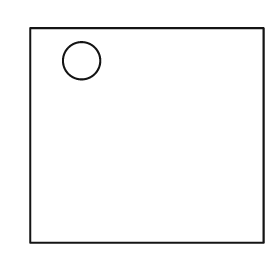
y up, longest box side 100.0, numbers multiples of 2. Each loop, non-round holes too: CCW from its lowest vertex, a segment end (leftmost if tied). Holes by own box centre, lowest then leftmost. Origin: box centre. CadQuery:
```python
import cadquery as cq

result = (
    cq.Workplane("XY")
    .moveTo(-50.0, -46.0)
    .lineTo(50.0, -46.0)
    .lineTo(50.0, 46.0)
    .lineTo(-50.0, 46.0)
    .close()
    .moveTo(-28.0, 32.0)
    .circle(8.0)
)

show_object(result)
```